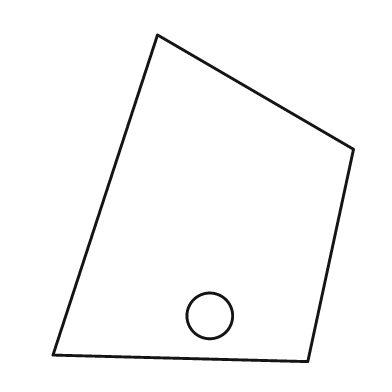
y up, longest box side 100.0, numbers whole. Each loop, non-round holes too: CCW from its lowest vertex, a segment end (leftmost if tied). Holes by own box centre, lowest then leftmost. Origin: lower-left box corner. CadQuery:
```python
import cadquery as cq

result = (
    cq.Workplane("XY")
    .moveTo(78.0, 0.0)
    .lineTo(92.0, 65.0)
    .lineTo(32.0, 100.0)
    .lineTo(0.0, 2.0)
    .close()
    .moveTo(48.0, 14.0)
    .circle(7.0)
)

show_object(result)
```